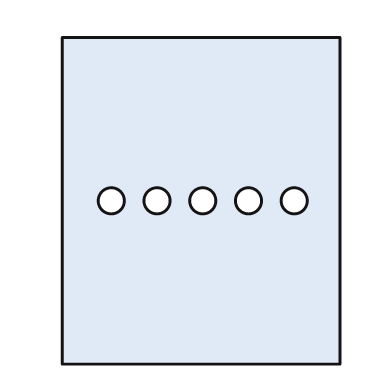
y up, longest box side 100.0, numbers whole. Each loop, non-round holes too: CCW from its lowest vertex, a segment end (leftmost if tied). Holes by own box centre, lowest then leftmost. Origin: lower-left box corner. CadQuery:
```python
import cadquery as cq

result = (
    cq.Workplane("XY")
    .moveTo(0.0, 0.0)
    .lineTo(85.0, 0.0)
    .lineTo(85.0, 100.0)
    .lineTo(0.0, 100.0)
    .close()
    .moveTo(15.0, 50.0)
    .circle(4.0)
    .moveTo(29.0, 50.0)
    .circle(4.0)
    .moveTo(43.0, 50.0)
    .circle(4.0)
    .moveTo(57.0, 50.0)
    .circle(4.0)
    .moveTo(71.0, 50.0)
    .circle(4.0)
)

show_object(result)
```